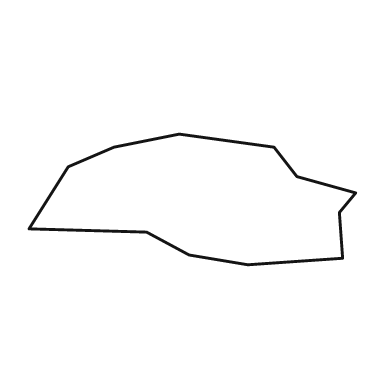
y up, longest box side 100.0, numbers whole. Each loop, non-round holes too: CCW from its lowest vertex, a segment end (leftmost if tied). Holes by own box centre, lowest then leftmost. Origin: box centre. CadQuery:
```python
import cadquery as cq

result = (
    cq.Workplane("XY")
    .moveTo(17.0, -20.0)
    .lineTo(46.0, -18.0)
    .lineTo(45.0, -4.0)
    .lineTo(50.0, 2.0)
    .lineTo(32.0, 7.0)
    .lineTo(25.0, 16.0)
    .lineTo(-4.0, 20.0)
    .lineTo(-24.0, 16.0)
    .lineTo(-38.0, 10.0)
    .lineTo(-50.0, -9.0)
    .lineTo(-14.0, -10.0)
    .lineTo(-1.0, -17.0)
    .close()
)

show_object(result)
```